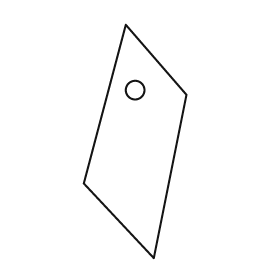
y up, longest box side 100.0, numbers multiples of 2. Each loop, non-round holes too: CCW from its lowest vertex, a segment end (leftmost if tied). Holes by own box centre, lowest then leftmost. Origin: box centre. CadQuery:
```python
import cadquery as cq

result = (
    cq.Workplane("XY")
    .moveTo(8.0, -50.0)
    .lineTo(22.0, 20.0)
    .lineTo(-4.0, 50.0)
    .lineTo(-22.0, -18.0)
    .close()
    .moveTo(0.0, 22.0)
    .circle(4.0)
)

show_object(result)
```